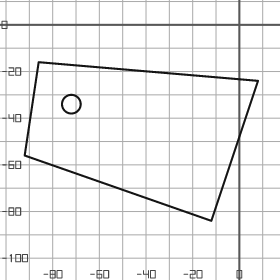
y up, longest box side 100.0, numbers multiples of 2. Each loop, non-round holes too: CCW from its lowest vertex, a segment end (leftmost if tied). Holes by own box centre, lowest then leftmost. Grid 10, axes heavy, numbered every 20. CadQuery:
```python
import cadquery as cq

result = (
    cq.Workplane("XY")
    .moveTo(-12.0, -84.0)
    .lineTo(8.0, -24.0)
    .lineTo(-86.0, -16.0)
    .lineTo(-92.0, -56.0)
    .close()
    .moveTo(-72.0, -34.0)
    .circle(4.0)
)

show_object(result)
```